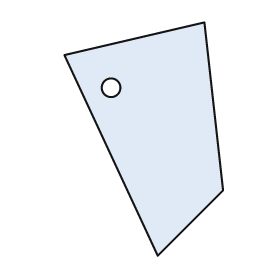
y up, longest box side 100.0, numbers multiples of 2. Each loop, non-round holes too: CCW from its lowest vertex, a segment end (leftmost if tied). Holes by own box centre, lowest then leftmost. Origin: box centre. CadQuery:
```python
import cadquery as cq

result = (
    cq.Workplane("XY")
    .moveTo(6.0, -50.0)
    .lineTo(34.0, -22.0)
    .lineTo(26.0, 50.0)
    .lineTo(-34.0, 36.0)
    .close()
    .moveTo(-14.0, 22.0)
    .circle(4.0)
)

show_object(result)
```